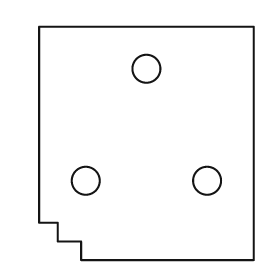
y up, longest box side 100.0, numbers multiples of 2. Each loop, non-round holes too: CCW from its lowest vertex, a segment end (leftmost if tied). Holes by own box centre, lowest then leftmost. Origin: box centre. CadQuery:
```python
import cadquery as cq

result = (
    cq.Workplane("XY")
    .moveTo(-28.0, -50.0)
    .lineTo(46.0, -50.0)
    .lineTo(46.0, 50.0)
    .lineTo(-46.0, 50.0)
    .lineTo(-46.0, -34.0)
    .lineTo(-38.0, -34.0)
    .lineTo(-38.0, -42.0)
    .lineTo(-28.0, -42.0)
    .close()
    .moveTo(-26.0, -16.0)
    .circle(6.0)
    .moveTo(26.0, -16.0)
    .circle(6.0)
    .moveTo(0.0, 32.0)
    .circle(6.0)
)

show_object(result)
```